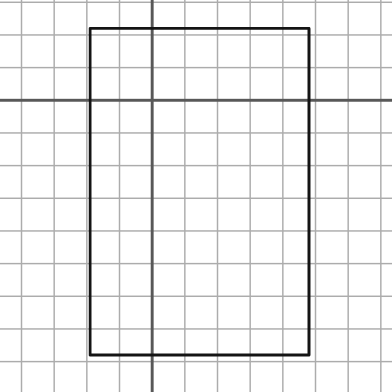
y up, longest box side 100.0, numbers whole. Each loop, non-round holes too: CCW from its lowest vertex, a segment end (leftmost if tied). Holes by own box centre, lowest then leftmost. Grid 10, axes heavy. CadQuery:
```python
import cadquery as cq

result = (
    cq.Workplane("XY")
    .moveTo(-19.0, -78.0)
    .lineTo(48.0, -78.0)
    .lineTo(48.0, 22.0)
    .lineTo(-19.0, 22.0)
    .close()
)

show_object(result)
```